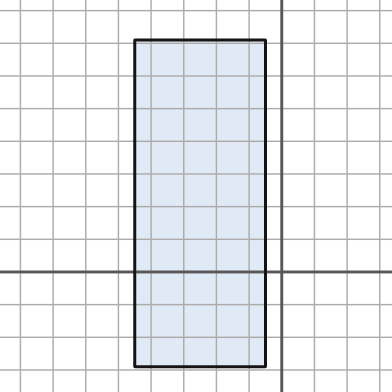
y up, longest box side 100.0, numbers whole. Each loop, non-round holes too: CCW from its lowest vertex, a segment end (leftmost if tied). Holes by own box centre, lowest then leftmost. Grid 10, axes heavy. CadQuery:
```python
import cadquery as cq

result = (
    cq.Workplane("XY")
    .moveTo(-45.0, -29.0)
    .lineTo(-5.0, -29.0)
    .lineTo(-5.0, 71.0)
    .lineTo(-45.0, 71.0)
    .close()
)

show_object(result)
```